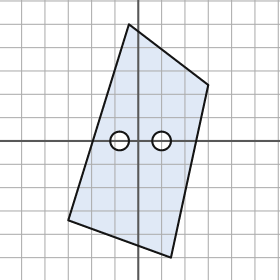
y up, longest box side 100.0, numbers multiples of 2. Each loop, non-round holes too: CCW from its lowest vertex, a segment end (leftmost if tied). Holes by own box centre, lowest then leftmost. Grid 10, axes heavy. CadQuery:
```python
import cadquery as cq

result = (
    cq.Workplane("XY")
    .moveTo(14.0, -50.0)
    .lineTo(30.0, 24.0)
    .lineTo(-4.0, 50.0)
    .lineTo(-30.0, -34.0)
    .close()
    .moveTo(-8.0, 0.0)
    .circle(4.0)
    .moveTo(10.0, 0.0)
    .circle(4.0)
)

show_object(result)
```